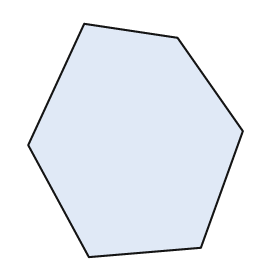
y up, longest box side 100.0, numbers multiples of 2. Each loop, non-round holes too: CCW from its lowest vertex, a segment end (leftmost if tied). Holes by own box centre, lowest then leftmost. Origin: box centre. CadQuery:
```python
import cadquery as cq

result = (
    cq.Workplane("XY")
    .moveTo(-20.0, -50.0)
    .lineTo(28.0, -46.0)
    .lineTo(46.0, 4.0)
    .lineTo(18.0, 44.0)
    .lineTo(-22.0, 50.0)
    .lineTo(-46.0, -2.0)
    .close()
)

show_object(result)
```